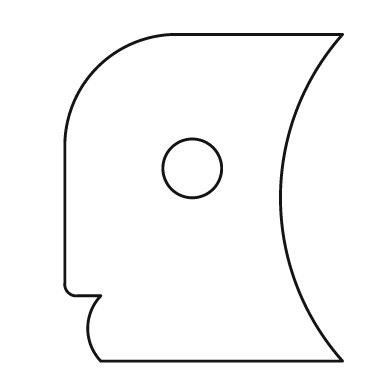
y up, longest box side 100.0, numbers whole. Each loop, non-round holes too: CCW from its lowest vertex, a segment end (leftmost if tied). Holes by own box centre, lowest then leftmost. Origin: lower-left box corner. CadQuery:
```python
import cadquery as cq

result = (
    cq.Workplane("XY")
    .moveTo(11.0, 0.0)
    .lineTo(85.0, 0.0)
    .threePointArc((66.0, 50.0), (85.0, 100.0))
    .lineTo(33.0, 100.0)
    .threePointArc((10.0, 90.0), (0.0, 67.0))
    .lineTo(0.0, 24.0)
    .threePointArc((1.0, 21.0), (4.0, 20.0))
    .lineTo(11.0, 20.0)
    .threePointArc((7.0, 10.0), (11.0, 0.0))
    .close()
    .moveTo(39.0, 59.0)
    .circle(9.0)
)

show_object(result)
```